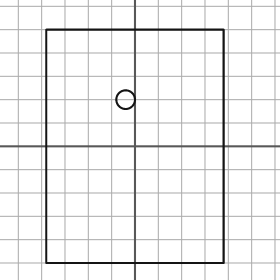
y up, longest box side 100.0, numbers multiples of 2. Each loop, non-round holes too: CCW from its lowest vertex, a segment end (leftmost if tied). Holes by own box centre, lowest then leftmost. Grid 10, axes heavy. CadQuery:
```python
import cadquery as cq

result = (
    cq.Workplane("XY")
    .moveTo(-38.0, -50.0)
    .lineTo(38.0, -50.0)
    .lineTo(38.0, 50.0)
    .lineTo(-38.0, 50.0)
    .close()
    .moveTo(-4.0, 20.0)
    .circle(4.0)
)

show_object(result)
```